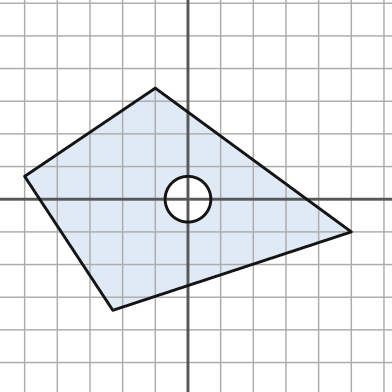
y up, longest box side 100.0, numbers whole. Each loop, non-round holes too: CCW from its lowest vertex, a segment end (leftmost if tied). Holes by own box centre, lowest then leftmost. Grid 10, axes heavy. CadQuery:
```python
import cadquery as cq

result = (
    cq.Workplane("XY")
    .moveTo(-23.0, -34.0)
    .lineTo(50.0, -10.0)
    .lineTo(-10.0, 34.0)
    .lineTo(-50.0, 7.0)
    .close()
    .moveTo(0.0, 0.0)
    .circle(7.0)
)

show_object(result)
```